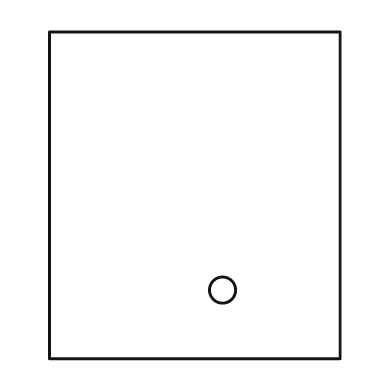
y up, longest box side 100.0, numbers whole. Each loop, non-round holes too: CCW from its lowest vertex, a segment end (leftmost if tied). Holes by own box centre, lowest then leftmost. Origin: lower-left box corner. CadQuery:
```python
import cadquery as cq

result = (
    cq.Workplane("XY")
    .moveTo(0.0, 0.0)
    .lineTo(89.0, 0.0)
    .lineTo(89.0, 100.0)
    .lineTo(0.0, 100.0)
    .close()
    .moveTo(53.0, 21.0)
    .circle(4.0)
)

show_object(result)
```